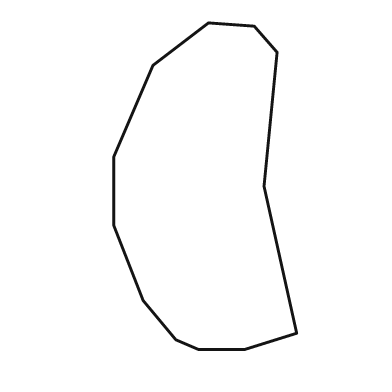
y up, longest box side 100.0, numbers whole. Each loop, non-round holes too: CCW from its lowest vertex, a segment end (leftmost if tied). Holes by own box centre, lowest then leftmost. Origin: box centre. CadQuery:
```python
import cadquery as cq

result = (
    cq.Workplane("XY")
    .moveTo(-2.0, -50.0)
    .lineTo(12.0, -50.0)
    .lineTo(28.0, -45.0)
    .lineTo(18.0, 0.0)
    .lineTo(22.0, 41.0)
    .lineTo(15.0, 49.0)
    .lineTo(1.0, 50.0)
    .lineTo(-16.0, 37.0)
    .lineTo(-28.0, 9.0)
    .lineTo(-28.0, -12.0)
    .lineTo(-19.0, -35.0)
    .lineTo(-9.0, -47.0)
    .close()
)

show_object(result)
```